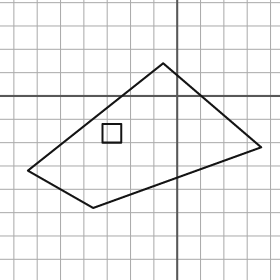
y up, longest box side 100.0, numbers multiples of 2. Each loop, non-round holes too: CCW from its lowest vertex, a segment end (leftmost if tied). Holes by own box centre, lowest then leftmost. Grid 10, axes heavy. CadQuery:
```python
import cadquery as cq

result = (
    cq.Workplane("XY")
    .moveTo(-36.0, -48.0)
    .lineTo(36.0, -22.0)
    .lineTo(-6.0, 14.0)
    .lineTo(-64.0, -32.0)
    .close()
    .moveTo(-32.0, -20.0)
    .lineTo(-24.0, -20.0)
    .lineTo(-24.0, -12.0)
    .lineTo(-32.0, -12.0)
    .close()
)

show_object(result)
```